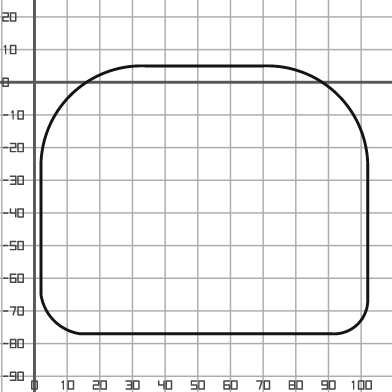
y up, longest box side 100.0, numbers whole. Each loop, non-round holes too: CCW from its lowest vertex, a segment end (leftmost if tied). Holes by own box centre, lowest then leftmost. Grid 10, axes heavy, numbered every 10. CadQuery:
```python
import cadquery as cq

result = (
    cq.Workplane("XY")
    .moveTo(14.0, -77.0)
    .lineTo(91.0, -77.0)
    .threePointArc((99.0, -74.0), (102.0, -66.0))
    .lineTo(102.0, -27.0)
    .threePointArc((93.0, -4.0), (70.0, 5.0))
    .lineTo(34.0, 5.0)
    .threePointArc((11.0, -4.0), (2.0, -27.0))
    .lineTo(2.0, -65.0)
    .threePointArc((6.0, -73.0), (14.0, -77.0))
    .close()
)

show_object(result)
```